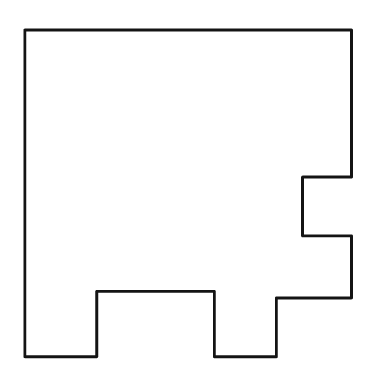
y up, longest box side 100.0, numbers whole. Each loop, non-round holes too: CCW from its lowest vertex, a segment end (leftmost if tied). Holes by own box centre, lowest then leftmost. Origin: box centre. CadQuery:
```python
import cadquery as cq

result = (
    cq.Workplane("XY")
    .moveTo(-50.0, -50.0)
    .lineTo(-28.0, -50.0)
    .lineTo(-28.0, -30.0)
    .lineTo(8.0, -30.0)
    .lineTo(8.0, -50.0)
    .lineTo(27.0, -50.0)
    .lineTo(27.0, -32.0)
    .lineTo(50.0, -32.0)
    .lineTo(50.0, -13.0)
    .lineTo(35.0, -13.0)
    .lineTo(35.0, 5.0)
    .lineTo(50.0, 5.0)
    .lineTo(50.0, 50.0)
    .lineTo(-50.0, 50.0)
    .close()
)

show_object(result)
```